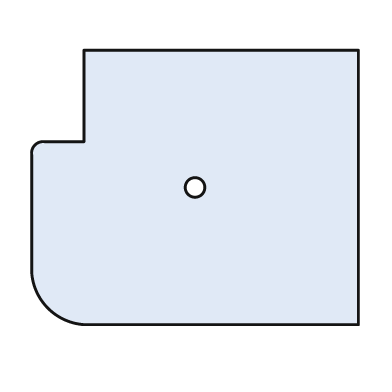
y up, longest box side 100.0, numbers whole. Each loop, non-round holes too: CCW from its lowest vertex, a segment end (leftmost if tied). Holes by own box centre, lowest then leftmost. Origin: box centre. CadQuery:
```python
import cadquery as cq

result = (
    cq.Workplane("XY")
    .moveTo(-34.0, -42.0)
    .lineTo(50.0, -42.0)
    .lineTo(50.0, 42.0)
    .lineTo(-34.0, 42.0)
    .lineTo(-34.0, 14.0)
    .lineTo(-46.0, 14.0)
    .threePointArc((-49.0, 13.0), (-50.0, 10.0))
    .lineTo(-50.0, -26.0)
    .threePointArc((-45.0, -37.0), (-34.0, -42.0))
    .close()
    .moveTo(0.0, 0.0)
    .circle(3.0)
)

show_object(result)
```